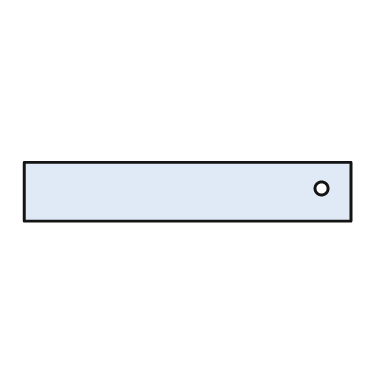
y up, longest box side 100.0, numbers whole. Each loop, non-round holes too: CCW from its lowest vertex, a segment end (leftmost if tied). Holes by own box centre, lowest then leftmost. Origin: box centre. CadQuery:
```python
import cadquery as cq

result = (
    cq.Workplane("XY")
    .moveTo(-50.0, -9.0)
    .lineTo(50.0, -9.0)
    .lineTo(50.0, 9.0)
    .lineTo(-50.0, 9.0)
    .close()
    .moveTo(41.0, 1.0)
    .circle(2.0)
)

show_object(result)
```